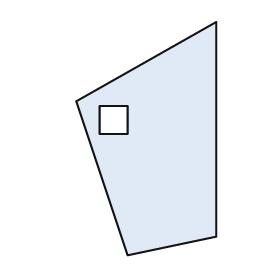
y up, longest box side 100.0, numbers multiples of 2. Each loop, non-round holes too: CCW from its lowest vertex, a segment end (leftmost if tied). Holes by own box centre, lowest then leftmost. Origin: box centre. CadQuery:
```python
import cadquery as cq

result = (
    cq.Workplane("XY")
    .moveTo(-8.0, -50.0)
    .lineTo(30.0, -42.0)
    .lineTo(30.0, 50.0)
    .lineTo(-30.0, 16.0)
    .close()
    .moveTo(-20.0, 2.0)
    .lineTo(-8.0, 2.0)
    .lineTo(-8.0, 14.0)
    .lineTo(-20.0, 14.0)
    .close()
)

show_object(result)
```